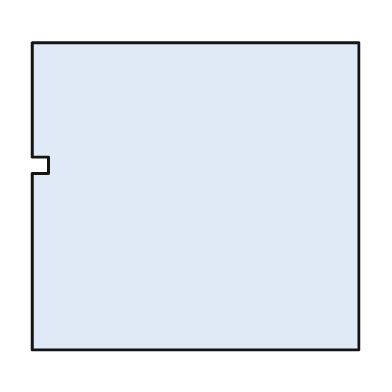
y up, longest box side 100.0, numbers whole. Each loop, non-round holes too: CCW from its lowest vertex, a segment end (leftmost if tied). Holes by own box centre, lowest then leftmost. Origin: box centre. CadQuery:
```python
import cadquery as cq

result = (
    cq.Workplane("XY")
    .moveTo(-50.0, -47.0)
    .lineTo(50.0, -47.0)
    .lineTo(50.0, 47.0)
    .lineTo(-50.0, 47.0)
    .lineTo(-50.0, 12.0)
    .lineTo(-45.0, 12.0)
    .lineTo(-45.0, 7.0)
    .lineTo(-50.0, 7.0)
    .close()
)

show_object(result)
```